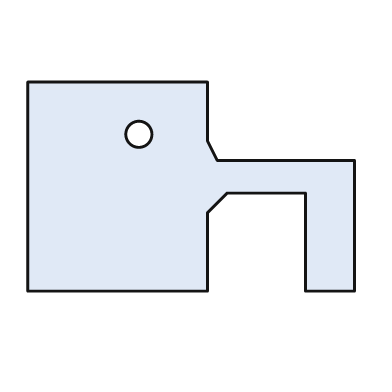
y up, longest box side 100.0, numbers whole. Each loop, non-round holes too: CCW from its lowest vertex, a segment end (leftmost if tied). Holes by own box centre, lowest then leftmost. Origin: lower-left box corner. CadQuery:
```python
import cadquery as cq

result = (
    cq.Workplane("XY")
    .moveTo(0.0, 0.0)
    .lineTo(55.0, 0.0)
    .lineTo(55.0, 24.0)
    .lineTo(61.0, 30.0)
    .lineTo(85.0, 30.0)
    .lineTo(85.0, 0.0)
    .lineTo(100.0, 0.0)
    .lineTo(100.0, 40.0)
    .lineTo(58.0, 40.0)
    .lineTo(55.0, 46.0)
    .lineTo(55.0, 64.0)
    .lineTo(0.0, 64.0)
    .close()
    .moveTo(34.0, 48.0)
    .circle(4.0)
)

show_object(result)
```